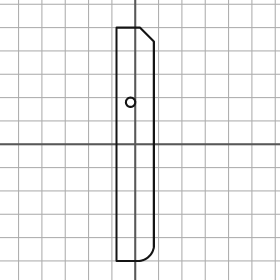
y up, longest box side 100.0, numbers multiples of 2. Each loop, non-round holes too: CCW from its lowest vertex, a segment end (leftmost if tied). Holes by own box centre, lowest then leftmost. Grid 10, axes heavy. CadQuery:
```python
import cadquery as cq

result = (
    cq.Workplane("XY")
    .moveTo(-8.0, -50.0)
    .lineTo(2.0, -50.0)
    .threePointArc((6.0, -48.0), (8.0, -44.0))
    .lineTo(8.0, 44.0)
    .lineTo(2.0, 50.0)
    .lineTo(-8.0, 50.0)
    .close()
    .moveTo(-2.0, 18.0)
    .circle(2.0)
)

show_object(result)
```